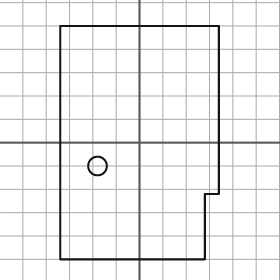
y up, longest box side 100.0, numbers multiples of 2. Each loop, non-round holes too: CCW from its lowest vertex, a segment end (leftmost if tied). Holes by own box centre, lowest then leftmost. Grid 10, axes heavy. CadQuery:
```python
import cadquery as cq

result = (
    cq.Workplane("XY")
    .moveTo(-34.0, -50.0)
    .lineTo(28.0, -50.0)
    .lineTo(28.0, -22.0)
    .lineTo(34.0, -22.0)
    .lineTo(34.0, 50.0)
    .lineTo(-34.0, 50.0)
    .close()
    .moveTo(-18.0, -10.0)
    .circle(4.0)
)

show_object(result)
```